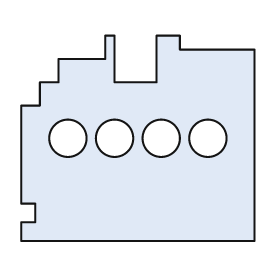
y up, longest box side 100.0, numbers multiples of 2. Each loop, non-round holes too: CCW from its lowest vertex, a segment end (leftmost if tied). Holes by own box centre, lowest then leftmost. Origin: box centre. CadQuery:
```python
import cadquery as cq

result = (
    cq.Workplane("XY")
    .moveTo(-50.0, -44.0)
    .lineTo(50.0, -44.0)
    .lineTo(50.0, 38.0)
    .lineTo(18.0, 38.0)
    .lineTo(18.0, 44.0)
    .lineTo(8.0, 44.0)
    .lineTo(8.0, 24.0)
    .lineTo(-10.0, 24.0)
    .lineTo(-10.0, 44.0)
    .lineTo(-14.0, 44.0)
    .lineTo(-14.0, 34.0)
    .lineTo(-34.0, 34.0)
    .lineTo(-34.0, 24.0)
    .lineTo(-42.0, 24.0)
    .lineTo(-42.0, 14.0)
    .lineTo(-50.0, 14.0)
    .lineTo(-50.0, -28.0)
    .lineTo(-44.0, -28.0)
    .lineTo(-44.0, -36.0)
    .lineTo(-50.0, -36.0)
    .close()
    .moveTo(-30.0, 0.0)
    .circle(8.0)
    .moveTo(-10.0, 0.0)
    .circle(8.0)
    .moveTo(10.0, 0.0)
    .circle(8.0)
    .moveTo(30.0, 0.0)
    .circle(8.0)
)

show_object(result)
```